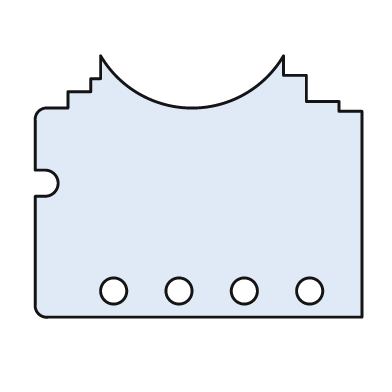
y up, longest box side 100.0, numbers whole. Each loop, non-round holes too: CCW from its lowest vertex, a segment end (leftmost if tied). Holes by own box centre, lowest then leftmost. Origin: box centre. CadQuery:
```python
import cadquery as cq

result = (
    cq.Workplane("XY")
    .moveTo(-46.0, -40.0)
    .lineTo(50.0, -40.0)
    .lineTo(50.0, 23.0)
    .lineTo(43.0, 23.0)
    .lineTo(43.0, 26.0)
    .lineTo(33.0, 26.0)
    .lineTo(33.0, 34.0)
    .lineTo(26.0, 34.0)
    .lineTo(26.0, 40.0)
    .threePointArc((-2.0, 24.0), (-30.0, 40.0))
    .lineTo(-30.0, 33.0)
    .lineTo(-33.0, 33.0)
    .lineTo(-33.0, 29.0)
    .lineTo(-40.0, 29.0)
    .lineTo(-40.0, 24.0)
    .lineTo(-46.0, 24.0)
    .threePointArc((-49.0, 23.0), (-50.0, 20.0))
    .lineTo(-50.0, 5.0)
    .lineTo(-47.0, 5.0)
    .threePointArc((-43.0, 1.0), (-47.0, -3.0))
    .lineTo(-50.0, -3.0)
    .lineTo(-50.0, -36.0)
    .threePointArc((-49.0, -39.0), (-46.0, -40.0))
    .close()
    .moveTo(-26.0, -32.0)
    .circle(4.0)
    .moveTo(-6.0, -32.0)
    .circle(4.0)
    .moveTo(14.0, -32.0)
    .circle(4.0)
    .moveTo(34.0, -32.0)
    .circle(4.0)
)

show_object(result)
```